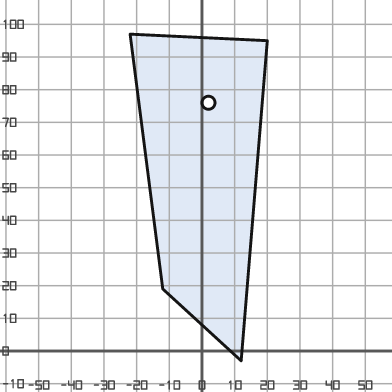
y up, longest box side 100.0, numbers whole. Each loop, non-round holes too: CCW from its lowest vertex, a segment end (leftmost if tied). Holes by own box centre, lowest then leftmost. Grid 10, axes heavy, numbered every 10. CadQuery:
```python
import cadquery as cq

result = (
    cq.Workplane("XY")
    .moveTo(12.0, -3.0)
    .lineTo(20.0, 95.0)
    .lineTo(-22.0, 97.0)
    .lineTo(-12.0, 19.0)
    .close()
    .moveTo(2.0, 76.0)
    .circle(2.0)
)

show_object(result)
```